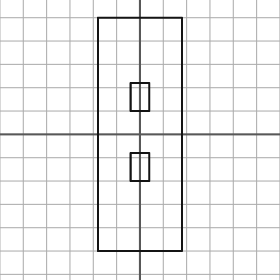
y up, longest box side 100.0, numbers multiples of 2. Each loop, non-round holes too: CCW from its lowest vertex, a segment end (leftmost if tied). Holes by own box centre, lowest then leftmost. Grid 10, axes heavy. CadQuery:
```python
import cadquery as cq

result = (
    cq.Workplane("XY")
    .moveTo(-18.0, -50.0)
    .lineTo(18.0, -50.0)
    .lineTo(18.0, 50.0)
    .lineTo(-18.0, 50.0)
    .close()
    .moveTo(-4.0, -20.0)
    .lineTo(4.0, -20.0)
    .lineTo(4.0, -8.0)
    .lineTo(-4.0, -8.0)
    .close()
    .moveTo(-4.0, 10.0)
    .lineTo(4.0, 10.0)
    .lineTo(4.0, 22.0)
    .lineTo(-4.0, 22.0)
    .close()
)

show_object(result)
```